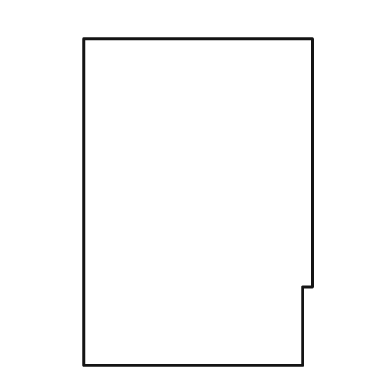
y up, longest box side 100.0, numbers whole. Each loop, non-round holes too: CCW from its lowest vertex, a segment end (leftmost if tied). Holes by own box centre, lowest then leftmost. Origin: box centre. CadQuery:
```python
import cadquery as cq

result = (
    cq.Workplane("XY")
    .moveTo(-35.0, -50.0)
    .lineTo(32.0, -50.0)
    .lineTo(32.0, -26.0)
    .lineTo(35.0, -26.0)
    .lineTo(35.0, 50.0)
    .lineTo(-35.0, 50.0)
    .close()
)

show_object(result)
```